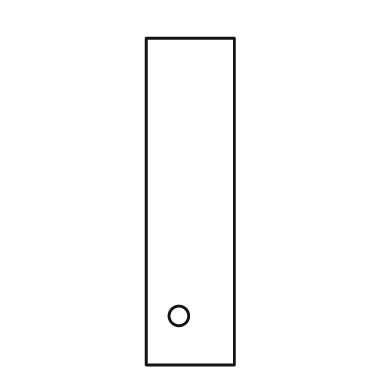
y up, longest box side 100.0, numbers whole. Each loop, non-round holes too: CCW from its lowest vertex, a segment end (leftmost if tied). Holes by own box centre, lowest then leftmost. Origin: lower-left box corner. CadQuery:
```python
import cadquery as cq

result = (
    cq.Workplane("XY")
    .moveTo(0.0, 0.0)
    .lineTo(27.0, 0.0)
    .lineTo(27.0, 100.0)
    .lineTo(0.0, 100.0)
    .close()
    .moveTo(10.0, 15.0)
    .circle(3.0)
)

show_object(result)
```